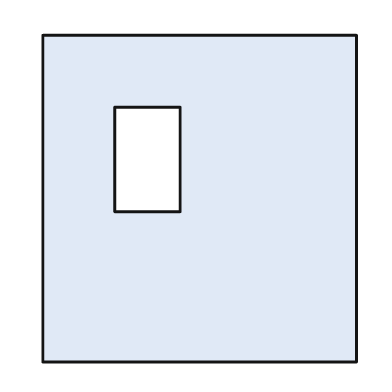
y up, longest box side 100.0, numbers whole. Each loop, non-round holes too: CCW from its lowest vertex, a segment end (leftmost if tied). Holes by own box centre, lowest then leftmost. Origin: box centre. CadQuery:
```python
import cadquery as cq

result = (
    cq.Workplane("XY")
    .moveTo(-48.0, -50.0)
    .lineTo(48.0, -50.0)
    .lineTo(48.0, 50.0)
    .lineTo(-48.0, 50.0)
    .close()
    .moveTo(-26.0, -4.0)
    .lineTo(-6.0, -4.0)
    .lineTo(-6.0, 28.0)
    .lineTo(-26.0, 28.0)
    .close()
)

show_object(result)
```